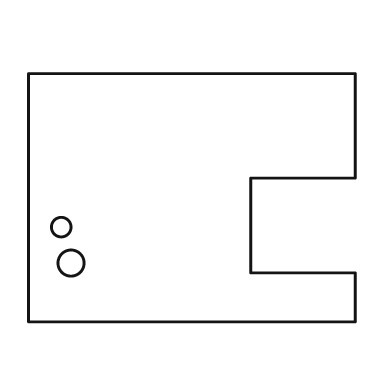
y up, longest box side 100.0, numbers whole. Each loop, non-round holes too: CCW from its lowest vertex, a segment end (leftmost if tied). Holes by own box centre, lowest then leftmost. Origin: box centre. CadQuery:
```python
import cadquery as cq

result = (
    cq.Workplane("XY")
    .moveTo(-50.0, -38.0)
    .lineTo(50.0, -38.0)
    .lineTo(50.0, -23.0)
    .lineTo(18.0, -23.0)
    .lineTo(18.0, 6.0)
    .lineTo(50.0, 6.0)
    .lineTo(50.0, 38.0)
    .lineTo(-50.0, 38.0)
    .close()
    .moveTo(-37.0, -20.0)
    .circle(4.0)
    .moveTo(-40.0, -9.0)
    .circle(3.0)
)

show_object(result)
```